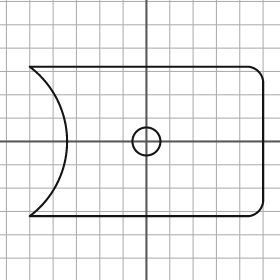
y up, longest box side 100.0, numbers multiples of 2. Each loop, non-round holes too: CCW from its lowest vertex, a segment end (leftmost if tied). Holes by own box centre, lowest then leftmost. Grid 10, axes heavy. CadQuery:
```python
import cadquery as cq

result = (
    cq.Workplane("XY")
    .moveTo(-50.0, -32.0)
    .lineTo(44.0, -32.0)
    .threePointArc((48.0, -30.0), (50.0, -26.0))
    .lineTo(50.0, 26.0)
    .threePointArc((48.0, 30.0), (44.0, 32.0))
    .lineTo(-50.0, 32.0)
    .threePointArc((-34.0, 0.0), (-50.0, -32.0))
    .close()
    .moveTo(0.0, 0.0)
    .circle(6.0)
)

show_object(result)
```